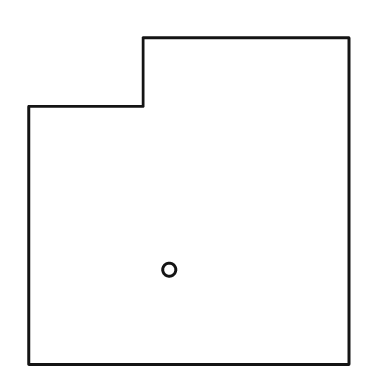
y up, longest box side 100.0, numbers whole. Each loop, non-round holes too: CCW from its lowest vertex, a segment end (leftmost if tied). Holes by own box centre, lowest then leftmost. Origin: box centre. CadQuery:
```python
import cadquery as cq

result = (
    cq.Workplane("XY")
    .moveTo(-49.0, -50.0)
    .lineTo(49.0, -50.0)
    .lineTo(49.0, 50.0)
    .lineTo(-14.0, 50.0)
    .lineTo(-14.0, 29.0)
    .lineTo(-49.0, 29.0)
    .close()
    .moveTo(-6.0, -21.0)
    .circle(2.0)
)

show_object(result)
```